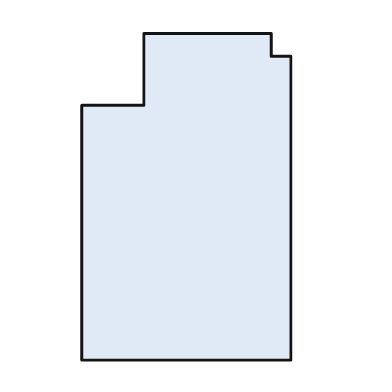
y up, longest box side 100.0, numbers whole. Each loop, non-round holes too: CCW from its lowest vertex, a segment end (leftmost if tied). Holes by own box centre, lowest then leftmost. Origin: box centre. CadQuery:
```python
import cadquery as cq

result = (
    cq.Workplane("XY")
    .moveTo(-32.0, -50.0)
    .lineTo(32.0, -50.0)
    .lineTo(32.0, 43.0)
    .lineTo(26.0, 43.0)
    .lineTo(26.0, 50.0)
    .lineTo(-13.0, 50.0)
    .lineTo(-13.0, 28.0)
    .lineTo(-32.0, 28.0)
    .close()
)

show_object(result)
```